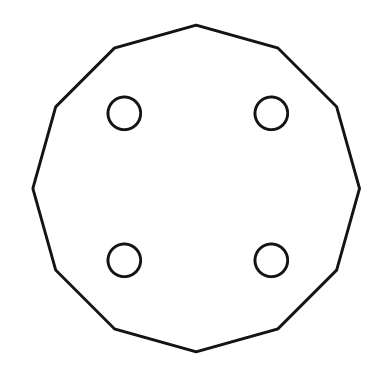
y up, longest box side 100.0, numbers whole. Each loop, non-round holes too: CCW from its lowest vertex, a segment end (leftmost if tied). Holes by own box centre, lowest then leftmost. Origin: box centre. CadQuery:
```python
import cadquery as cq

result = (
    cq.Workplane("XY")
    .moveTo(0.0, -50.0)
    .lineTo(25.0, -43.0)
    .lineTo(43.0, -25.0)
    .lineTo(50.0, 0.0)
    .lineTo(43.0, 25.0)
    .lineTo(25.0, 43.0)
    .lineTo(0.0, 50.0)
    .lineTo(-25.0, 43.0)
    .lineTo(-43.0, 25.0)
    .lineTo(-50.0, 0.0)
    .lineTo(-43.0, -25.0)
    .lineTo(-25.0, -43.0)
    .close()
    .moveTo(-22.0, -22.0)
    .circle(5.0)
    .moveTo(23.0, -22.0)
    .circle(5.0)
    .moveTo(-22.0, 23.0)
    .circle(5.0)
    .moveTo(23.0, 23.0)
    .circle(5.0)
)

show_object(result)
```